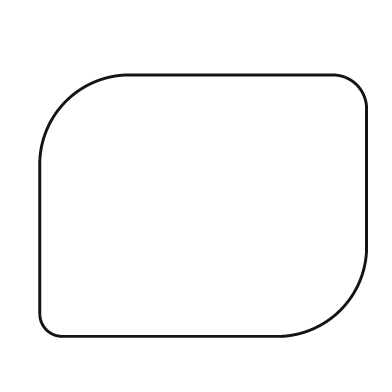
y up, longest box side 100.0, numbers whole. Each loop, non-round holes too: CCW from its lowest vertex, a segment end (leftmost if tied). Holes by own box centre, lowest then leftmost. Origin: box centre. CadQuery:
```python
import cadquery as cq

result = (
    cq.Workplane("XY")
    .moveTo(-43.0, -40.0)
    .lineTo(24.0, -40.0)
    .threePointArc((42.0, -32.0), (50.0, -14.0))
    .lineTo(50.0, 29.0)
    .threePointArc((47.0, 37.0), (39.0, 40.0))
    .lineTo(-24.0, 40.0)
    .threePointArc((-42.0, 32.0), (-50.0, 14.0))
    .lineTo(-50.0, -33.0)
    .threePointArc((-48.0, -38.0), (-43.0, -40.0))
    .close()
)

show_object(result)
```